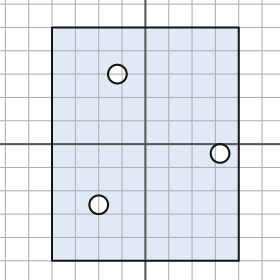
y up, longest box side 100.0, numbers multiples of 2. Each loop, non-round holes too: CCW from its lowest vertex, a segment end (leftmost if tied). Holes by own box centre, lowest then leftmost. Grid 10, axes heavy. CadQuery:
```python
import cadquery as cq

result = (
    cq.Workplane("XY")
    .moveTo(-40.0, -50.0)
    .lineTo(40.0, -50.0)
    .lineTo(40.0, 50.0)
    .lineTo(-40.0, 50.0)
    .close()
    .moveTo(-20.0, -26.0)
    .circle(4.0)
    .moveTo(32.0, -4.0)
    .circle(4.0)
    .moveTo(-12.0, 30.0)
    .circle(4.0)
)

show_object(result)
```